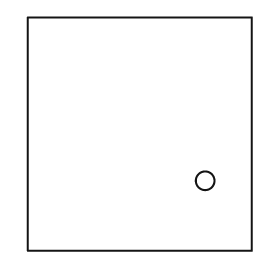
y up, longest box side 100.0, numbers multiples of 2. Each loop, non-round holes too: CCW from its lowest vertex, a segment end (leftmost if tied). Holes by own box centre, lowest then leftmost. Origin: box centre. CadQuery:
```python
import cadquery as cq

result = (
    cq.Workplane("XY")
    .moveTo(-48.0, -50.0)
    .lineTo(48.0, -50.0)
    .lineTo(48.0, 50.0)
    .lineTo(-48.0, 50.0)
    .close()
    .moveTo(28.0, -20.0)
    .circle(4.0)
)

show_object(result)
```